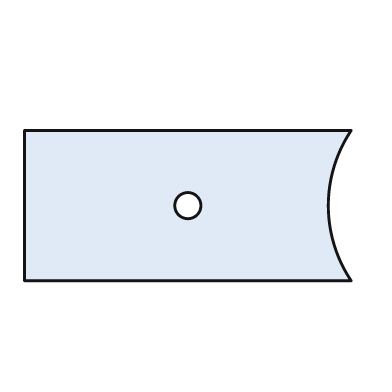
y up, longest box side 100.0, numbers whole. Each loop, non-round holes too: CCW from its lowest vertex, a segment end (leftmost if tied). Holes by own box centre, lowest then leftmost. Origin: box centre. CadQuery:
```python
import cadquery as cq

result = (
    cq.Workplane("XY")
    .moveTo(-50.0, -23.0)
    .lineTo(50.0, -23.0)
    .threePointArc((43.0, 0.0), (50.0, 23.0))
    .lineTo(-50.0, 23.0)
    .close()
    .moveTo(0.0, 0.0)
    .circle(4.0)
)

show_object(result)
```